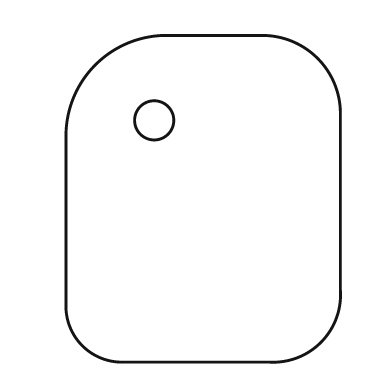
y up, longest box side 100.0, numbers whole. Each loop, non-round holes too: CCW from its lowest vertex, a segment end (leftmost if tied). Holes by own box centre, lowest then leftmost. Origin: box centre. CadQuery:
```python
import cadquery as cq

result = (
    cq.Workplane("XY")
    .moveTo(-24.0, -50.0)
    .lineTo(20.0, -50.0)
    .threePointArc((36.0, -44.0), (42.0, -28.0))
    .lineTo(42.0, 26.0)
    .threePointArc((35.0, 43.0), (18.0, 50.0))
    .lineTo(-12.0, 50.0)
    .threePointArc((-33.0, 41.0), (-42.0, 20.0))
    .lineTo(-42.0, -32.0)
    .threePointArc((-37.0, -45.0), (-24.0, -50.0))
    .close()
    .moveTo(-15.0, 24.0)
    .circle(6.0)
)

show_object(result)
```